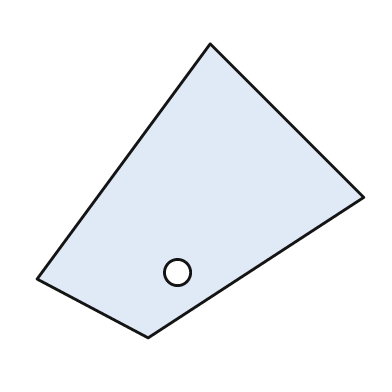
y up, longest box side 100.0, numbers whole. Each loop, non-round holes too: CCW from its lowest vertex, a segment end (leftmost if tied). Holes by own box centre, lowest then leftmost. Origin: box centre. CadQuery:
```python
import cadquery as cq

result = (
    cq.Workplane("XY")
    .moveTo(-16.0, -45.0)
    .lineTo(50.0, -2.0)
    .lineTo(3.0, 45.0)
    .lineTo(-50.0, -27.0)
    .close()
    .moveTo(-7.0, -25.0)
    .circle(4.0)
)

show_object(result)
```